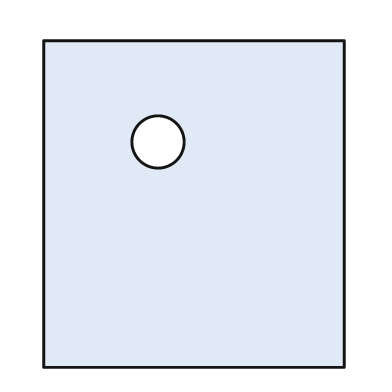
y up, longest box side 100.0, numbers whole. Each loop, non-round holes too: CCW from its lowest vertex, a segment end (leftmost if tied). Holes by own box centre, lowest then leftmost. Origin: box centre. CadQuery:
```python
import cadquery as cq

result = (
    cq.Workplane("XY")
    .moveTo(-46.0, -50.0)
    .lineTo(46.0, -50.0)
    .lineTo(46.0, 50.0)
    .lineTo(-46.0, 50.0)
    .close()
    .moveTo(-11.0, 19.0)
    .circle(8.0)
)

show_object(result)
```